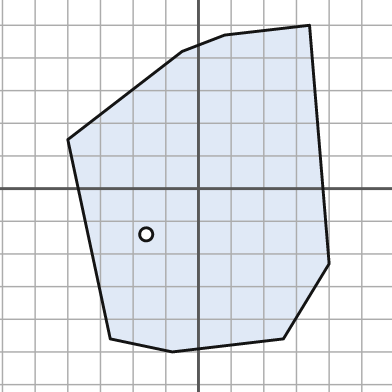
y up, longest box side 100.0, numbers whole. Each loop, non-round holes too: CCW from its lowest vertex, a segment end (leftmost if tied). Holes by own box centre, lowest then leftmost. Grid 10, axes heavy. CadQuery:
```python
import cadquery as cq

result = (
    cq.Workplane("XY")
    .moveTo(-8.0, -50.0)
    .lineTo(26.0, -46.0)
    .lineTo(40.0, -23.0)
    .lineTo(34.0, 50.0)
    .lineTo(8.0, 47.0)
    .lineTo(-5.0, 42.0)
    .lineTo(-40.0, 15.0)
    .lineTo(-27.0, -46.0)
    .close()
    .moveTo(-16.0, -14.0)
    .circle(2.0)
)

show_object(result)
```